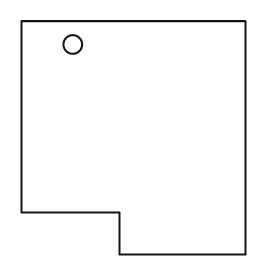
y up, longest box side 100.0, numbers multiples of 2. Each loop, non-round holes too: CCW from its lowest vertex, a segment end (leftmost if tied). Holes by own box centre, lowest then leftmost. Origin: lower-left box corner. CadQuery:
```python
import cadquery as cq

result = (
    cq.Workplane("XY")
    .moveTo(42.0, 0.0)
    .lineTo(96.0, 0.0)
    .lineTo(96.0, 100.0)
    .lineTo(0.0, 100.0)
    .lineTo(0.0, 18.0)
    .lineTo(42.0, 18.0)
    .close()
    .moveTo(22.0, 90.0)
    .circle(4.0)
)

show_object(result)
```